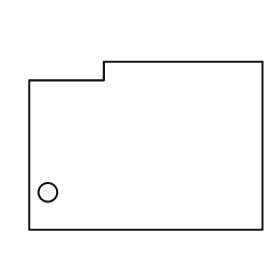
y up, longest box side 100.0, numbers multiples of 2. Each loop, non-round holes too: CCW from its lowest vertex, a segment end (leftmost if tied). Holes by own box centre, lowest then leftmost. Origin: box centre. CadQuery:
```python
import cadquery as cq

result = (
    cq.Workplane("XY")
    .moveTo(-50.0, -36.0)
    .lineTo(50.0, -36.0)
    .lineTo(50.0, 36.0)
    .lineTo(-18.0, 36.0)
    .lineTo(-18.0, 28.0)
    .lineTo(-50.0, 28.0)
    .close()
    .moveTo(-42.0, -20.0)
    .circle(4.0)
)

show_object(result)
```